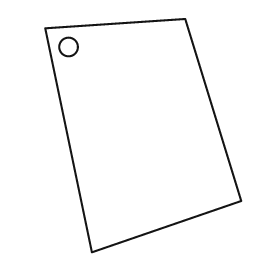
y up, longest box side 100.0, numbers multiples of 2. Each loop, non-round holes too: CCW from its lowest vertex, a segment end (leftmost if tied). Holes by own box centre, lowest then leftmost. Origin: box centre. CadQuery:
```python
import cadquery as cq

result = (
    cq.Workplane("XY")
    .moveTo(-22.0, -50.0)
    .lineTo(42.0, -28.0)
    .lineTo(18.0, 50.0)
    .lineTo(-42.0, 46.0)
    .close()
    .moveTo(-32.0, 38.0)
    .circle(4.0)
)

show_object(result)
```